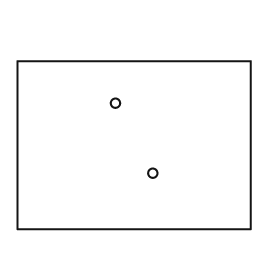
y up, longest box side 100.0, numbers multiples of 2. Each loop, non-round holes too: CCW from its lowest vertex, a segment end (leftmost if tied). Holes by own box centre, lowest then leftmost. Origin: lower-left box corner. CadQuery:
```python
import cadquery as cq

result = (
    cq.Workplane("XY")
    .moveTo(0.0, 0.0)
    .lineTo(100.0, 0.0)
    .lineTo(100.0, 72.0)
    .lineTo(0.0, 72.0)
    .close()
    .moveTo(58.0, 24.0)
    .circle(2.0)
    .moveTo(42.0, 54.0)
    .circle(2.0)
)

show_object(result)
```